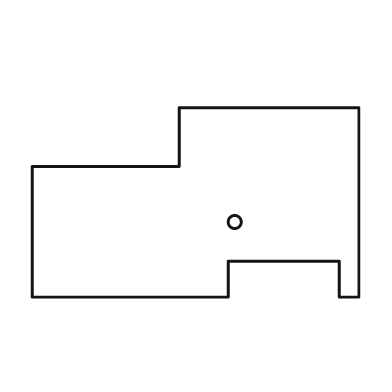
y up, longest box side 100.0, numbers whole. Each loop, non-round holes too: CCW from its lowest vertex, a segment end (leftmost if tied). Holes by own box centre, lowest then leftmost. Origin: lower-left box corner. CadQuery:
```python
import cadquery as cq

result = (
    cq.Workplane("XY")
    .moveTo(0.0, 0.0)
    .lineTo(60.0, 0.0)
    .lineTo(60.0, 11.0)
    .lineTo(94.0, 11.0)
    .lineTo(94.0, 0.0)
    .lineTo(100.0, 0.0)
    .lineTo(100.0, 58.0)
    .lineTo(45.0, 58.0)
    .lineTo(45.0, 40.0)
    .lineTo(0.0, 40.0)
    .close()
    .moveTo(62.0, 23.0)
    .circle(2.0)
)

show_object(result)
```